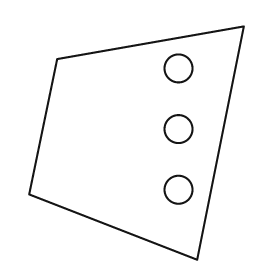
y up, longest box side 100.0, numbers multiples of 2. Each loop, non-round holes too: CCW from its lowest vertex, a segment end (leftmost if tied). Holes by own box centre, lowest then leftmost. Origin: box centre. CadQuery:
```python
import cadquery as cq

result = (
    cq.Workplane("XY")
    .moveTo(26.0, -50.0)
    .lineTo(46.0, 50.0)
    .lineTo(-34.0, 36.0)
    .lineTo(-46.0, -22.0)
    .close()
    .moveTo(18.0, -20.0)
    .circle(6.0)
    .moveTo(18.0, 6.0)
    .circle(6.0)
    .moveTo(18.0, 32.0)
    .circle(6.0)
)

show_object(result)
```